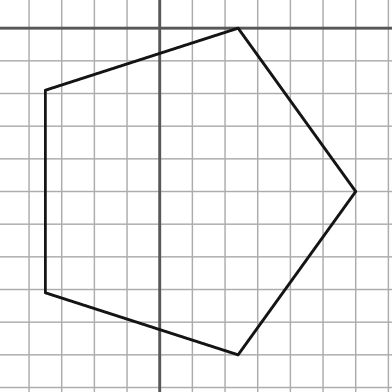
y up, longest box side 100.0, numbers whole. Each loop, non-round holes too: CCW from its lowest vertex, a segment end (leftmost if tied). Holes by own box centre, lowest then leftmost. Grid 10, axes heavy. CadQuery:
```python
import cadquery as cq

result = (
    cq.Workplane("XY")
    .moveTo(24.0, -100.0)
    .lineTo(60.0, -50.0)
    .lineTo(24.0, 0.0)
    .lineTo(-35.0, -19.0)
    .lineTo(-35.0, -81.0)
    .close()
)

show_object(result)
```